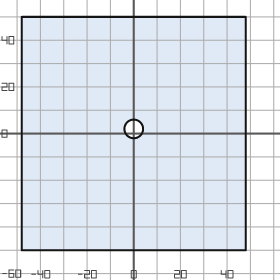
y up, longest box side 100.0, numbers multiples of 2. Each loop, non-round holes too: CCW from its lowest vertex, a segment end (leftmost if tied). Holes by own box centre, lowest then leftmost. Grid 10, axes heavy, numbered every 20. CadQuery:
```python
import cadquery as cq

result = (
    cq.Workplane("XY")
    .moveTo(-48.0, -50.0)
    .lineTo(48.0, -50.0)
    .lineTo(48.0, 50.0)
    .lineTo(-48.0, 50.0)
    .close()
    .moveTo(0.0, 2.0)
    .circle(4.0)
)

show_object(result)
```